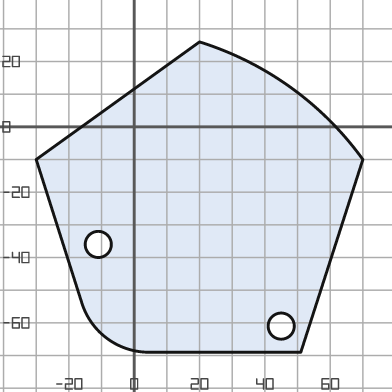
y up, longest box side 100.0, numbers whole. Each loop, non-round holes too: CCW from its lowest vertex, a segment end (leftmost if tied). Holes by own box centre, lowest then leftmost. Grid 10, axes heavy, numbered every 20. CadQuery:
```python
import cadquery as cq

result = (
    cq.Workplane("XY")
    .moveTo(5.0, -69.0)
    .lineTo(51.0, -69.0)
    .lineTo(70.0, -10.0)
    .threePointArc((48.0, 12.0), (20.0, 26.0))
    .lineTo(-30.0, -10.0)
    .lineTo(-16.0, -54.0)
    .threePointArc((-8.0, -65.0), (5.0, -69.0))
    .close()
    .moveTo(45.0, -61.0)
    .circle(4.0)
    .moveTo(-11.0, -36.0)
    .circle(4.0)
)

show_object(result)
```